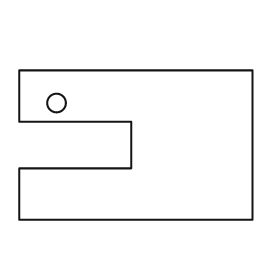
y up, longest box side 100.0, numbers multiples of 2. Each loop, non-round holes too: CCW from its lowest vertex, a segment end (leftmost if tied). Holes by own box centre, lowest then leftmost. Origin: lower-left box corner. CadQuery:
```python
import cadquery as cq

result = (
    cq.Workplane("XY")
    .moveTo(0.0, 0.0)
    .lineTo(100.0, 0.0)
    .lineTo(100.0, 64.0)
    .lineTo(0.0, 64.0)
    .lineTo(0.0, 42.0)
    .lineTo(48.0, 42.0)
    .lineTo(48.0, 22.0)
    .lineTo(0.0, 22.0)
    .close()
    .moveTo(16.0, 50.0)
    .circle(4.0)
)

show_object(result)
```